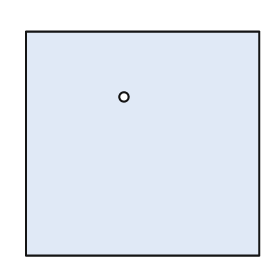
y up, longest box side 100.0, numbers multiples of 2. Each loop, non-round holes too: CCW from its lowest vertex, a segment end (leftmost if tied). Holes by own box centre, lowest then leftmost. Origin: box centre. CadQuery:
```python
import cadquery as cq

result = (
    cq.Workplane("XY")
    .moveTo(-50.0, -48.0)
    .lineTo(50.0, -48.0)
    .lineTo(50.0, 48.0)
    .lineTo(-50.0, 48.0)
    .close()
    .moveTo(-8.0, 20.0)
    .circle(2.0)
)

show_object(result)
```